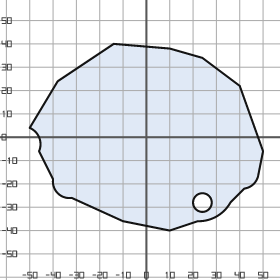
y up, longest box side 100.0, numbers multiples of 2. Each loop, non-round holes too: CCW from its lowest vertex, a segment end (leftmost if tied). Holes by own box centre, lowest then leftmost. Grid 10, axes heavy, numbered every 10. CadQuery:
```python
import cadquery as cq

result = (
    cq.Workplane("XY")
    .moveTo(10.0, -40.0)
    .lineTo(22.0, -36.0)
    .threePointArc((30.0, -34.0), (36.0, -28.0))
    .lineTo(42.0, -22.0)
    .threePointArc((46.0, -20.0), (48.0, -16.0))
    .lineTo(50.0, -6.0)
    .lineTo(40.0, 22.0)
    .lineTo(24.0, 34.0)
    .lineTo(10.0, 38.0)
    .lineTo(-14.0, 40.0)
    .lineTo(-38.0, 24.0)
    .lineTo(-50.0, 4.0)
    .threePointArc((-46.0, 0.0), (-46.0, -6.0))
    .lineTo(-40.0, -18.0)
    .threePointArc((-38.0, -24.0), (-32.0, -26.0))
    .lineTo(-10.0, -36.0)
    .close()
    .moveTo(24.0, -28.0)
    .circle(4.0)
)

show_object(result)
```